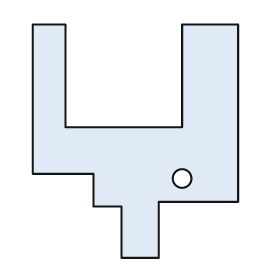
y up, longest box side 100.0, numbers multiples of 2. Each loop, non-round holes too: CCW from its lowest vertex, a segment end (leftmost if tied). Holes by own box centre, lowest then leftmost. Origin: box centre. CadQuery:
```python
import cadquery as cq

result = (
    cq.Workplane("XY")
    .moveTo(-6.0, -50.0)
    .lineTo(10.0, -50.0)
    .lineTo(10.0, -26.0)
    .lineTo(44.0, -26.0)
    .lineTo(44.0, 50.0)
    .lineTo(20.0, 50.0)
    .lineTo(20.0, 6.0)
    .lineTo(-30.0, 6.0)
    .lineTo(-30.0, 50.0)
    .lineTo(-44.0, 50.0)
    .lineTo(-44.0, -14.0)
    .lineTo(-18.0, -14.0)
    .lineTo(-18.0, -28.0)
    .lineTo(-6.0, -28.0)
    .close()
    .moveTo(20.0, -16.0)
    .circle(4.0)
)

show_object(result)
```